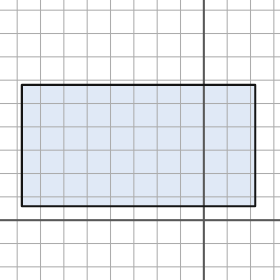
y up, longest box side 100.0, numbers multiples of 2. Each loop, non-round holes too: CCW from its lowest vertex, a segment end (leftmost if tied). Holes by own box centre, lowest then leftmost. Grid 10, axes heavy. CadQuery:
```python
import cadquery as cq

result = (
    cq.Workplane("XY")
    .moveTo(-78.0, 6.0)
    .lineTo(22.0, 6.0)
    .lineTo(22.0, 58.0)
    .lineTo(-78.0, 58.0)
    .close()
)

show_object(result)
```